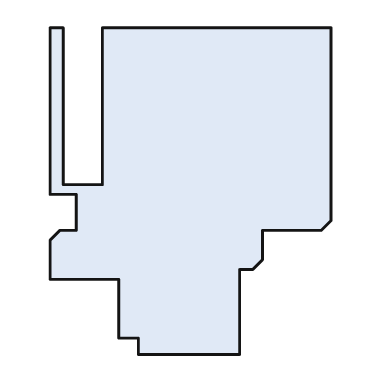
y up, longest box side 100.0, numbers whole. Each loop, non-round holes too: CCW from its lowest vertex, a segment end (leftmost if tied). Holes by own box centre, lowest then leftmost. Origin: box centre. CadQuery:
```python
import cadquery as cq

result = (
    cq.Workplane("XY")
    .moveTo(-16.0, -50.0)
    .lineTo(15.0, -50.0)
    .lineTo(15.0, -24.0)
    .lineTo(19.0, -24.0)
    .lineTo(22.0, -21.0)
    .lineTo(22.0, -12.0)
    .lineTo(40.0, -12.0)
    .lineTo(43.0, -9.0)
    .lineTo(43.0, 50.0)
    .lineTo(-27.0, 50.0)
    .lineTo(-27.0, 2.0)
    .lineTo(-39.0, 2.0)
    .lineTo(-39.0, 50.0)
    .lineTo(-43.0, 50.0)
    .lineTo(-43.0, -1.0)
    .lineTo(-35.0, -1.0)
    .lineTo(-35.0, -12.0)
    .lineTo(-40.0, -12.0)
    .lineTo(-43.0, -15.0)
    .lineTo(-43.0, -27.0)
    .lineTo(-22.0, -27.0)
    .lineTo(-22.0, -45.0)
    .lineTo(-16.0, -45.0)
    .close()
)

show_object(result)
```